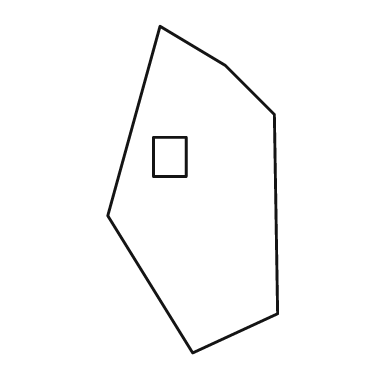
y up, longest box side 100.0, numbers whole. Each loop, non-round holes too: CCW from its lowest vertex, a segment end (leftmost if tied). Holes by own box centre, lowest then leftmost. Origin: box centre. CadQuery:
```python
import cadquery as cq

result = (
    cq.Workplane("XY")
    .moveTo(0.0, -50.0)
    .lineTo(26.0, -38.0)
    .lineTo(25.0, 23.0)
    .lineTo(10.0, 38.0)
    .lineTo(-10.0, 50.0)
    .lineTo(-26.0, -8.0)
    .close()
    .moveTo(-12.0, 4.0)
    .lineTo(-2.0, 4.0)
    .lineTo(-2.0, 16.0)
    .lineTo(-12.0, 16.0)
    .close()
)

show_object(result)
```